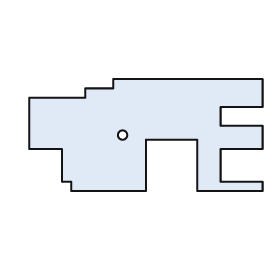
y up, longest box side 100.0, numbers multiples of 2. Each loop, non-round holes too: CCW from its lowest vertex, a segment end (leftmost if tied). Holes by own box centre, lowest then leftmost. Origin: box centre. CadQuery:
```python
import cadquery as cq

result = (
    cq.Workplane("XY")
    .moveTo(-32.0, -24.0)
    .lineTo(0.0, -24.0)
    .lineTo(0.0, -2.0)
    .lineTo(22.0, -2.0)
    .lineTo(22.0, -24.0)
    .lineTo(50.0, -24.0)
    .lineTo(50.0, -20.0)
    .lineTo(32.0, -20.0)
    .lineTo(32.0, -6.0)
    .lineTo(50.0, -6.0)
    .lineTo(50.0, 4.0)
    .lineTo(32.0, 4.0)
    .lineTo(32.0, 12.0)
    .lineTo(50.0, 12.0)
    .lineTo(50.0, 24.0)
    .lineTo(-14.0, 24.0)
    .lineTo(-14.0, 20.0)
    .lineTo(-26.0, 20.0)
    .lineTo(-26.0, 16.0)
    .lineTo(-50.0, 16.0)
    .lineTo(-50.0, -6.0)
    .lineTo(-36.0, -6.0)
    .lineTo(-36.0, -20.0)
    .lineTo(-32.0, -20.0)
    .close()
    .moveTo(-10.0, 0.0)
    .circle(2.0)
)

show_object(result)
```